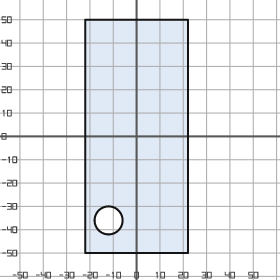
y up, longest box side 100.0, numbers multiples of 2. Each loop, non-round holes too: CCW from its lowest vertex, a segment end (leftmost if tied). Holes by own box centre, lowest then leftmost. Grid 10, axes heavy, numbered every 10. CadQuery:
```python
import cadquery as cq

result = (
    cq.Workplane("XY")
    .moveTo(-22.0, -50.0)
    .lineTo(22.0, -50.0)
    .lineTo(22.0, 50.0)
    .lineTo(-22.0, 50.0)
    .close()
    .moveTo(-12.0, -36.0)
    .circle(6.0)
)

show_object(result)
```